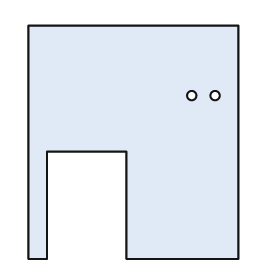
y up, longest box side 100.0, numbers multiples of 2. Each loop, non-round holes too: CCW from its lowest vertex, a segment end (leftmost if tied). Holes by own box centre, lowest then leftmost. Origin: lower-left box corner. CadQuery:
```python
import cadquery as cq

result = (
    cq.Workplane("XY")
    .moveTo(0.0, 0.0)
    .lineTo(8.0, 0.0)
    .lineTo(8.0, 46.0)
    .lineTo(42.0, 46.0)
    .lineTo(42.0, 0.0)
    .lineTo(90.0, 0.0)
    .lineTo(90.0, 100.0)
    .lineTo(0.0, 100.0)
    .close()
    .moveTo(70.0, 70.0)
    .circle(2.0)
    .moveTo(80.0, 70.0)
    .circle(2.0)
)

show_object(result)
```